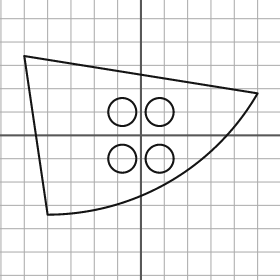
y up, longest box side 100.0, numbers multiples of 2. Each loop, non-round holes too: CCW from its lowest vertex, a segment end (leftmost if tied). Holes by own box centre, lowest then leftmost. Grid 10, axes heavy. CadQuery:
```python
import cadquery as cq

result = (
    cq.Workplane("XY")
    .moveTo(-40.0, -34.0)
    .threePointArc((12.0, -20.0), (50.0, 18.0))
    .lineTo(-50.0, 34.0)
    .close()
    .moveTo(-8.0, -10.0)
    .circle(6.0)
    .moveTo(8.0, -10.0)
    .circle(6.0)
    .moveTo(-8.0, 10.0)
    .circle(6.0)
    .moveTo(8.0, 10.0)
    .circle(6.0)
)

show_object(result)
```